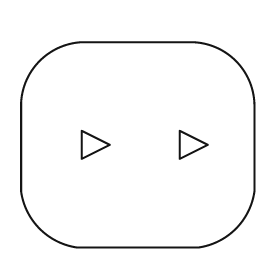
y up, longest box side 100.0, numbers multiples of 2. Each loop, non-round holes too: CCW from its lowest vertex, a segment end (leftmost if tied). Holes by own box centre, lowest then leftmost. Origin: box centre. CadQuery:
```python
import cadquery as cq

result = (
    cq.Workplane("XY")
    .moveTo(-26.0, -44.0)
    .lineTo(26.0, -44.0)
    .threePointArc((42.0, -36.0), (50.0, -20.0))
    .lineTo(50.0, 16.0)
    .threePointArc((42.0, 36.0), (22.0, 44.0))
    .lineTo(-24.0, 44.0)
    .threePointArc((-42.0, 36.0), (-50.0, 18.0))
    .lineTo(-50.0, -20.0)
    .threePointArc((-42.0, -36.0), (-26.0, -44.0))
    .close()
    .moveTo(-24.0, -6.0)
    .lineTo(-12.0, 0.0)
    .lineTo(-24.0, 6.0)
    .close()
    .moveTo(18.0, -6.0)
    .lineTo(30.0, 0.0)
    .lineTo(18.0, 6.0)
    .close()
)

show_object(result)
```